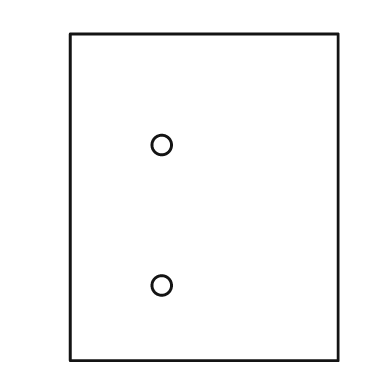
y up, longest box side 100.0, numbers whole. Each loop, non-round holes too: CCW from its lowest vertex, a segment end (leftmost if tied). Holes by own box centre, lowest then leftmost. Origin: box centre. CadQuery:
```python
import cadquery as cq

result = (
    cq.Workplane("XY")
    .moveTo(-41.0, -50.0)
    .lineTo(41.0, -50.0)
    .lineTo(41.0, 50.0)
    .lineTo(-41.0, 50.0)
    .close()
    .moveTo(-13.0, -27.0)
    .circle(3.0)
    .moveTo(-13.0, 16.0)
    .circle(3.0)
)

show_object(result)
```